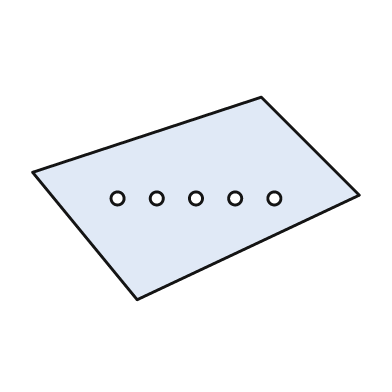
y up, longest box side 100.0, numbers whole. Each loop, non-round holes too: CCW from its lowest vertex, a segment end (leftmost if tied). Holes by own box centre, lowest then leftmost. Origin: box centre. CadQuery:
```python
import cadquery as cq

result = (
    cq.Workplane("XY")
    .moveTo(-18.0, -31.0)
    .lineTo(50.0, 1.0)
    .lineTo(20.0, 31.0)
    .lineTo(-50.0, 8.0)
    .close()
    .moveTo(-24.0, 0.0)
    .circle(2.0)
    .moveTo(-12.0, 0.0)
    .circle(2.0)
    .moveTo(0.0, 0.0)
    .circle(2.0)
    .moveTo(12.0, 0.0)
    .circle(2.0)
    .moveTo(24.0, 0.0)
    .circle(2.0)
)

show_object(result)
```